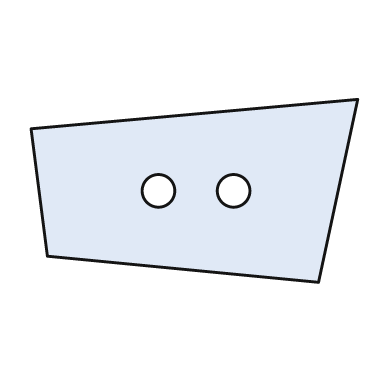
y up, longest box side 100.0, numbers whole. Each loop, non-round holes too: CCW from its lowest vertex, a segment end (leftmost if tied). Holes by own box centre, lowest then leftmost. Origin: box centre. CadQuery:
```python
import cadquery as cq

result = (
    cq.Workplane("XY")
    .moveTo(38.0, -28.0)
    .lineTo(50.0, 28.0)
    .lineTo(-50.0, 19.0)
    .lineTo(-45.0, -20.0)
    .close()
    .moveTo(-11.0, 0.0)
    .circle(5.0)
    .moveTo(12.0, 0.0)
    .circle(5.0)
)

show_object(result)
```